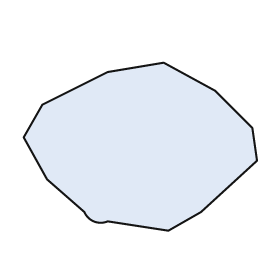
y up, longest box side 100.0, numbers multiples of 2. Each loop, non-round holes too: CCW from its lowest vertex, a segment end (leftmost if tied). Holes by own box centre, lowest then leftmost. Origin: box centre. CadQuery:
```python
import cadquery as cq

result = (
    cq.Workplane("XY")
    .moveTo(12.0, -36.0)
    .lineTo(26.0, -28.0)
    .lineTo(50.0, -6.0)
    .lineTo(48.0, 8.0)
    .lineTo(32.0, 24.0)
    .lineTo(10.0, 36.0)
    .lineTo(-14.0, 32.0)
    .lineTo(-42.0, 18.0)
    .lineTo(-50.0, 4.0)
    .lineTo(-40.0, -14.0)
    .lineTo(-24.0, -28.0)
    .threePointArc((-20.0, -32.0), (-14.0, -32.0))
    .close()
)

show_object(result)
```